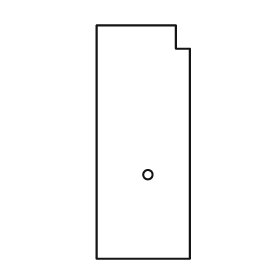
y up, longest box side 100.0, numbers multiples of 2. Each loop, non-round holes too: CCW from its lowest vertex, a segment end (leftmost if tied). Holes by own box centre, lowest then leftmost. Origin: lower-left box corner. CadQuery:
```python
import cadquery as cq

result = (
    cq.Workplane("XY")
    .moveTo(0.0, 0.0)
    .lineTo(40.0, 0.0)
    .lineTo(40.0, 90.0)
    .lineTo(34.0, 90.0)
    .lineTo(34.0, 100.0)
    .lineTo(0.0, 100.0)
    .close()
    .moveTo(22.0, 36.0)
    .circle(2.0)
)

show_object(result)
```